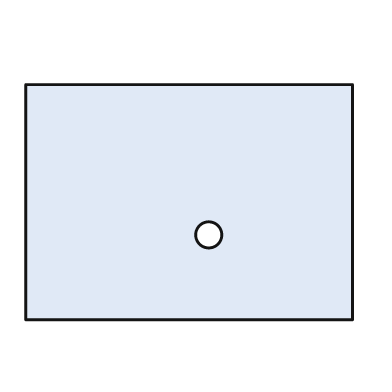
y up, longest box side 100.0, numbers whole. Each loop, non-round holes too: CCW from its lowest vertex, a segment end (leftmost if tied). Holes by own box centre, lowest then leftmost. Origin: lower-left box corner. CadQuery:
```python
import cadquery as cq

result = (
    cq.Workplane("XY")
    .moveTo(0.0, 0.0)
    .lineTo(100.0, 0.0)
    .lineTo(100.0, 72.0)
    .lineTo(0.0, 72.0)
    .close()
    .moveTo(56.0, 26.0)
    .circle(4.0)
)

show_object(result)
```